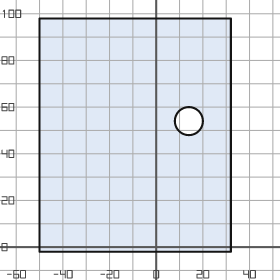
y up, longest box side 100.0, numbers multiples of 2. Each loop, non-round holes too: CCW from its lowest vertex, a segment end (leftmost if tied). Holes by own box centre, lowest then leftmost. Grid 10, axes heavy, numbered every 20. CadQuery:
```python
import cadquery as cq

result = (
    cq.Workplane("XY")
    .moveTo(-50.0, -2.0)
    .lineTo(32.0, -2.0)
    .lineTo(32.0, 98.0)
    .lineTo(-50.0, 98.0)
    .close()
    .moveTo(14.0, 54.0)
    .circle(6.0)
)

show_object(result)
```